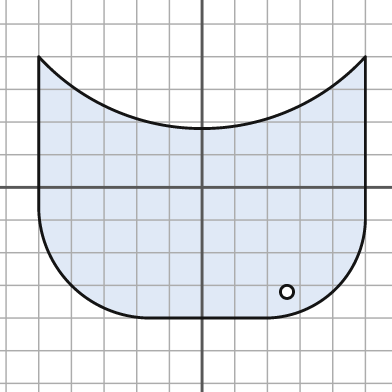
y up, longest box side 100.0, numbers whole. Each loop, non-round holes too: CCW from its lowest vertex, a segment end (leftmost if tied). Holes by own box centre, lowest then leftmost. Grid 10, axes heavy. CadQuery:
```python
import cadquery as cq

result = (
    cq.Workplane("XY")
    .moveTo(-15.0, -40.0)
    .lineTo(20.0, -40.0)
    .threePointArc((41.0, -31.0), (50.0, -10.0))
    .lineTo(50.0, 40.0)
    .threePointArc((0.0, 18.0), (-50.0, 40.0))
    .lineTo(-50.0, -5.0)
    .threePointArc((-40.0, -30.0), (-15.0, -40.0))
    .close()
    .moveTo(26.0, -32.0)
    .circle(2.0)
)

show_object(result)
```